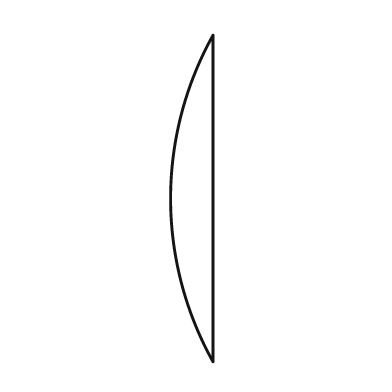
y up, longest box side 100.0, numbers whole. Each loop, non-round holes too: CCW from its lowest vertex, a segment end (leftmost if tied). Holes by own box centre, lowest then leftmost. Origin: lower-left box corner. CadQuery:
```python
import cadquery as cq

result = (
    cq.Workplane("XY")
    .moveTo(13.0, 0.0)
    .lineTo(13.0, 100.0)
    .threePointArc((0.0, 50.0), (13.0, 0.0))
    .close()
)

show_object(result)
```